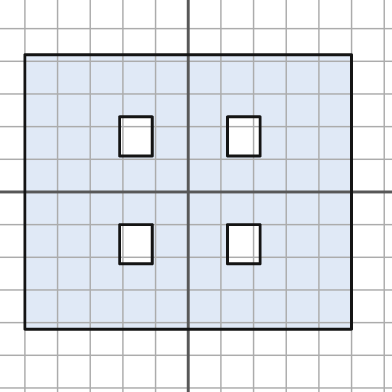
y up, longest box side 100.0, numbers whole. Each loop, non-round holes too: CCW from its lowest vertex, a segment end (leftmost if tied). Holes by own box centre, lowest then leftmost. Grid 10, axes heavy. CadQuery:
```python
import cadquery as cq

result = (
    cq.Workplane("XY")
    .moveTo(-50.0, -42.0)
    .lineTo(50.0, -42.0)
    .lineTo(50.0, 42.0)
    .lineTo(-50.0, 42.0)
    .close()
    .moveTo(-21.0, -22.0)
    .lineTo(-11.0, -22.0)
    .lineTo(-11.0, -10.0)
    .lineTo(-21.0, -10.0)
    .close()
    .moveTo(12.0, -22.0)
    .lineTo(22.0, -22.0)
    .lineTo(22.0, -10.0)
    .lineTo(12.0, -10.0)
    .close()
    .moveTo(-21.0, 11.0)
    .lineTo(-11.0, 11.0)
    .lineTo(-11.0, 23.0)
    .lineTo(-21.0, 23.0)
    .close()
    .moveTo(12.0, 11.0)
    .lineTo(22.0, 11.0)
    .lineTo(22.0, 23.0)
    .lineTo(12.0, 23.0)
    .close()
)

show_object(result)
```